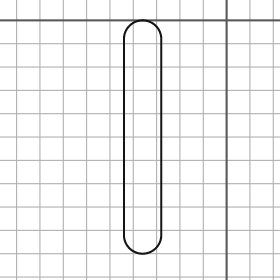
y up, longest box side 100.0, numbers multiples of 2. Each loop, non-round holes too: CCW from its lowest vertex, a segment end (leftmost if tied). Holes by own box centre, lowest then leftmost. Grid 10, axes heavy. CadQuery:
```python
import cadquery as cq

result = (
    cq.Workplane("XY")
    .moveTo(-44.0, -92.0)
    .threePointArc((-36.0, -100.0), (-28.0, -92.0))
    .lineTo(-28.0, -8.0)
    .threePointArc((-36.0, 0.0), (-44.0, -8.0))
    .close()
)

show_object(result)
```